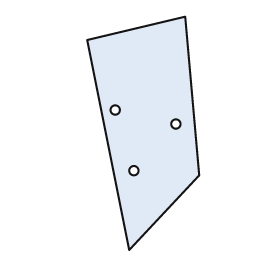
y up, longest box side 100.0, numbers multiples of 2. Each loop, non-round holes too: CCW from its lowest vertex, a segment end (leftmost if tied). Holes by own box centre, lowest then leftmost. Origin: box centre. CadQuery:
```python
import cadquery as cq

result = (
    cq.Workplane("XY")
    .moveTo(-6.0, -50.0)
    .lineTo(24.0, -18.0)
    .lineTo(18.0, 50.0)
    .lineTo(-24.0, 40.0)
    .close()
    .moveTo(-4.0, -16.0)
    .circle(2.0)
    .moveTo(14.0, 4.0)
    .circle(2.0)
    .moveTo(-12.0, 10.0)
    .circle(2.0)
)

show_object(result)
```